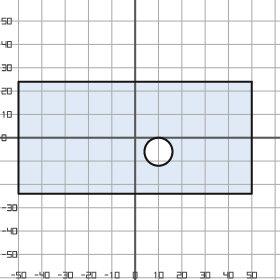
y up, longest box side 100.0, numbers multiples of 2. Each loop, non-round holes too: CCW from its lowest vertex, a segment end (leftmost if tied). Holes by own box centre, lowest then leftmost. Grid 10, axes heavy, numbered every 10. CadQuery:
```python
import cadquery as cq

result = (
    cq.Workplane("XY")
    .moveTo(-50.0, -24.0)
    .lineTo(50.0, -24.0)
    .lineTo(50.0, 24.0)
    .lineTo(-50.0, 24.0)
    .close()
    .moveTo(10.0, -6.0)
    .circle(6.0)
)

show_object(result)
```